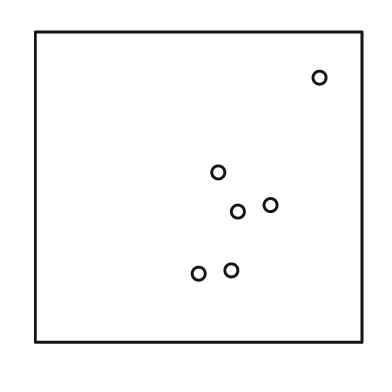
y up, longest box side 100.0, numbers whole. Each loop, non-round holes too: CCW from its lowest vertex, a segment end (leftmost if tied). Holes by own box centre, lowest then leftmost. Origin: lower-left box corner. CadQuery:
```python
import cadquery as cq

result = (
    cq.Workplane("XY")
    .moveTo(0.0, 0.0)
    .lineTo(100.0, 0.0)
    .lineTo(100.0, 95.0)
    .lineTo(0.0, 95.0)
    .close()
    .moveTo(50.0, 21.0)
    .circle(2.0)
    .moveTo(60.0, 22.0)
    .circle(2.0)
    .moveTo(62.0, 40.0)
    .circle(2.0)
    .moveTo(72.0, 42.0)
    .circle(2.0)
    .moveTo(56.0, 52.0)
    .circle(2.0)
    .moveTo(87.0, 81.0)
    .circle(2.0)
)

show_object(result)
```